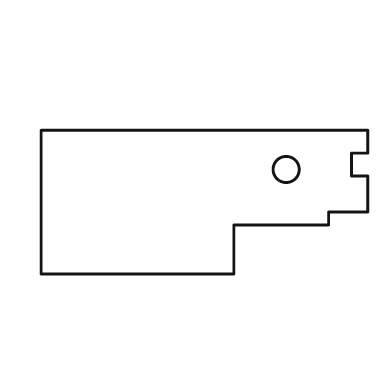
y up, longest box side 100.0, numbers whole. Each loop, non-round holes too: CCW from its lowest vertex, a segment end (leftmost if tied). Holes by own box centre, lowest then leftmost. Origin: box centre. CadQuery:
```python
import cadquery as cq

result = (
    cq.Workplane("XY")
    .moveTo(-50.0, -22.0)
    .lineTo(9.0, -22.0)
    .lineTo(9.0, -7.0)
    .lineTo(38.0, -7.0)
    .lineTo(38.0, -3.0)
    .lineTo(50.0, -3.0)
    .lineTo(50.0, 8.0)
    .lineTo(45.0, 8.0)
    .lineTo(45.0, 15.0)
    .lineTo(50.0, 15.0)
    .lineTo(50.0, 22.0)
    .lineTo(-50.0, 22.0)
    .close()
    .moveTo(25.0, 10.0)
    .circle(4.0)
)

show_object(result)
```